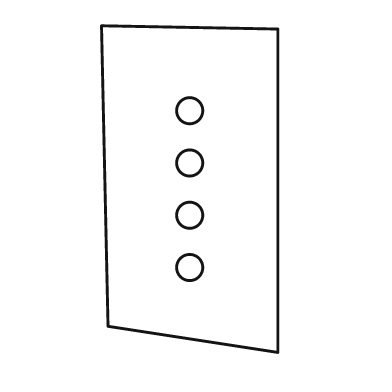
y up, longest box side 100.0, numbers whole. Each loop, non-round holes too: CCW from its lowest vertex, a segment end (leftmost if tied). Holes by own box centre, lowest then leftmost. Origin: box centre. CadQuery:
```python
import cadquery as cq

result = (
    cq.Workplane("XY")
    .moveTo(27.0, -50.0)
    .lineTo(27.0, 49.0)
    .lineTo(-27.0, 50.0)
    .lineTo(-25.0, -42.0)
    .close()
    .moveTo(0.0, -24.0)
    .circle(4.0)
    .moveTo(0.0, -8.0)
    .circle(4.0)
    .moveTo(0.0, 8.0)
    .circle(4.0)
    .moveTo(0.0, 24.0)
    .circle(4.0)
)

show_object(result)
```